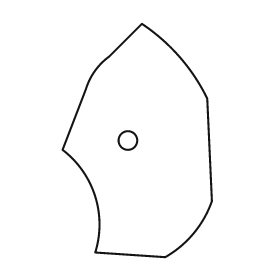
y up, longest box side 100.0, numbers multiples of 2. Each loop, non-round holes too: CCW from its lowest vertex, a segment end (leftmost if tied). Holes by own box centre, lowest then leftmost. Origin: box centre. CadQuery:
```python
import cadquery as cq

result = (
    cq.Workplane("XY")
    .moveTo(12.0, -50.0)
    .threePointArc((24.0, -40.0), (32.0, -26.0))
    .lineTo(30.0, 18.0)
    .threePointArc((18.0, 36.0), (2.0, 50.0))
    .lineTo(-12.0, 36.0)
    .threePointArc((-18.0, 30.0), (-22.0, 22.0))
    .lineTo(-32.0, -4.0)
    .threePointArc((-18.0, -24.0), (-18.0, -48.0))
    .close()
    .moveTo(-4.0, 0.0)
    .circle(4.0)
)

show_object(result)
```